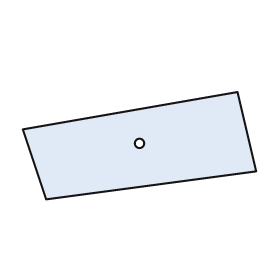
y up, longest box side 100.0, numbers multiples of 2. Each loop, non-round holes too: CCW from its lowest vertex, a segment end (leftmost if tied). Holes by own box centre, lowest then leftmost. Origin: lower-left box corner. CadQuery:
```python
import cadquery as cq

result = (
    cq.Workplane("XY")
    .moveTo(10.0, 0.0)
    .lineTo(100.0, 12.0)
    .lineTo(92.0, 46.0)
    .lineTo(0.0, 30.0)
    .close()
    .moveTo(50.0, 24.0)
    .circle(2.0)
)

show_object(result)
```